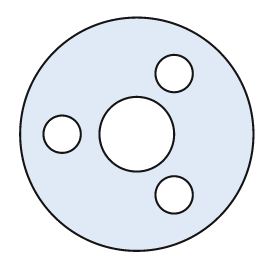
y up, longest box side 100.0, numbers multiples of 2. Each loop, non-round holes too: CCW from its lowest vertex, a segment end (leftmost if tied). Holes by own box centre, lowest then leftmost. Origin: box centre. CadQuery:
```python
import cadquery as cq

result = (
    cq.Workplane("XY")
    .moveTo(0.0, 0.0)
    .circle(50.0)
    .moveTo(16.0, -26.0)
    .circle(8.0)
    .moveTo(-32.0, 0.0)
    .circle(8.0)
    .moveTo(0.0, 0.0)
    .circle(16.0)
    .moveTo(16.0, 26.0)
    .circle(8.0)
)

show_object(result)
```